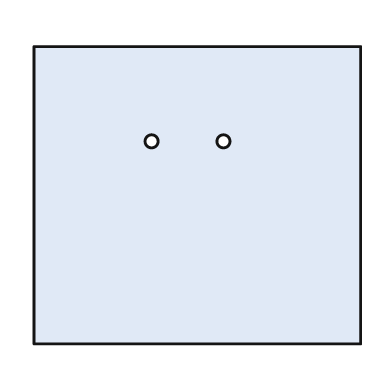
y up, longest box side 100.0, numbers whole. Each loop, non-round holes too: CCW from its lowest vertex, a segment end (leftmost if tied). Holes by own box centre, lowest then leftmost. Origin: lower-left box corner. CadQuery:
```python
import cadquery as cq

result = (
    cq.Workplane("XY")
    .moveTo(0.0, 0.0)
    .lineTo(100.0, 0.0)
    .lineTo(100.0, 91.0)
    .lineTo(0.0, 91.0)
    .close()
    .moveTo(36.0, 62.0)
    .circle(2.0)
    .moveTo(58.0, 62.0)
    .circle(2.0)
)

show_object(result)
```